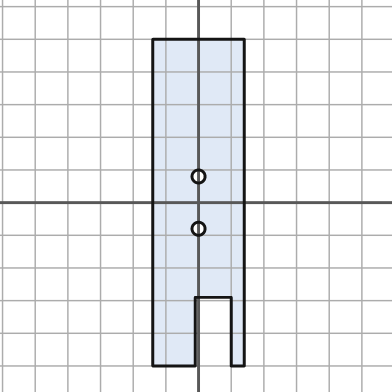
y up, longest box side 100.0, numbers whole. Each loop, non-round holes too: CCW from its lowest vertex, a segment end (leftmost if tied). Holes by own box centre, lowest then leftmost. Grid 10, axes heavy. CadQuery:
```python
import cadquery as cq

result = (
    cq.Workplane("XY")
    .moveTo(-14.0, -50.0)
    .lineTo(-1.0, -50.0)
    .lineTo(-1.0, -29.0)
    .lineTo(10.0, -29.0)
    .lineTo(10.0, -50.0)
    .lineTo(14.0, -50.0)
    .lineTo(14.0, 50.0)
    .lineTo(-14.0, 50.0)
    .close()
    .moveTo(0.0, -8.0)
    .circle(2.0)
    .moveTo(0.0, 8.0)
    .circle(2.0)
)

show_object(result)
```